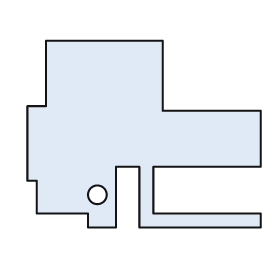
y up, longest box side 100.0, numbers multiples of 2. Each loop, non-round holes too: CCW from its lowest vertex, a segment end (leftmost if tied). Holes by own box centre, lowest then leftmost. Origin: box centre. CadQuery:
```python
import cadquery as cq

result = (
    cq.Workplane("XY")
    .moveTo(-24.0, -40.0)
    .lineTo(-12.0, -40.0)
    .lineTo(-12.0, -14.0)
    .lineTo(-2.0, -14.0)
    .lineTo(-2.0, -40.0)
    .lineTo(50.0, -40.0)
    .lineTo(50.0, -34.0)
    .lineTo(4.0, -34.0)
    .lineTo(4.0, -14.0)
    .lineTo(50.0, -14.0)
    .lineTo(50.0, 10.0)
    .lineTo(8.0, 10.0)
    .lineTo(8.0, 40.0)
    .lineTo(-42.0, 40.0)
    .lineTo(-42.0, 12.0)
    .lineTo(-50.0, 12.0)
    .lineTo(-50.0, -20.0)
    .lineTo(-46.0, -20.0)
    .lineTo(-46.0, -34.0)
    .lineTo(-24.0, -34.0)
    .close()
    .moveTo(-20.0, -26.0)
    .circle(4.0)
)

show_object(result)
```